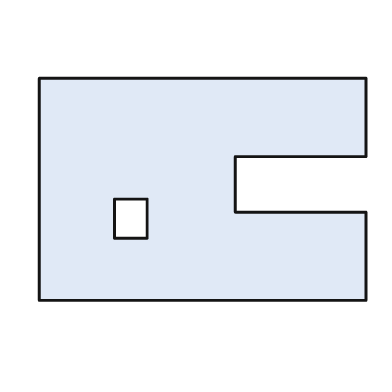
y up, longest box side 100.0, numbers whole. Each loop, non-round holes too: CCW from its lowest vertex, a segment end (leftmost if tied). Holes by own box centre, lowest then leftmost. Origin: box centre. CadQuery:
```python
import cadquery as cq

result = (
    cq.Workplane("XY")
    .moveTo(-50.0, -34.0)
    .lineTo(50.0, -34.0)
    .lineTo(50.0, -7.0)
    .lineTo(10.0, -7.0)
    .lineTo(10.0, 10.0)
    .lineTo(50.0, 10.0)
    .lineTo(50.0, 34.0)
    .lineTo(-50.0, 34.0)
    .close()
    .moveTo(-27.0, -15.0)
    .lineTo(-17.0, -15.0)
    .lineTo(-17.0, -3.0)
    .lineTo(-27.0, -3.0)
    .close()
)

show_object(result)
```